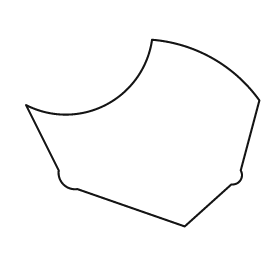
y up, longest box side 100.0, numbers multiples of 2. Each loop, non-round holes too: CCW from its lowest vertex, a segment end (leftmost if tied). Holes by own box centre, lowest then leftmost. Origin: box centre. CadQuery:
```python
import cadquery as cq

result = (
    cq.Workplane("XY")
    .moveTo(18.0, -40.0)
    .lineTo(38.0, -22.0)
    .threePointArc((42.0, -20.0), (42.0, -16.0))
    .lineTo(50.0, 14.0)
    .threePointArc((30.0, 32.0), (4.0, 40.0))
    .threePointArc((-16.0, 12.0), (-50.0, 12.0))
    .lineTo(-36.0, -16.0)
    .threePointArc((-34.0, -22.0), (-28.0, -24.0))
    .close()
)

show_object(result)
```